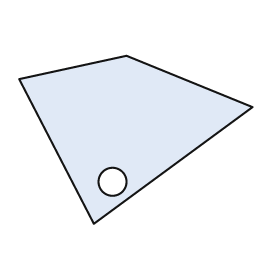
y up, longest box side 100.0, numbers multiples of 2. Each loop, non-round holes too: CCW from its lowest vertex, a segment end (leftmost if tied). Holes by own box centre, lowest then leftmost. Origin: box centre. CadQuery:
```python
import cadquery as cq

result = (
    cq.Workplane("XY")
    .moveTo(-18.0, -36.0)
    .lineTo(50.0, 14.0)
    .lineTo(-4.0, 36.0)
    .lineTo(-50.0, 26.0)
    .close()
    .moveTo(-10.0, -18.0)
    .circle(6.0)
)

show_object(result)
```